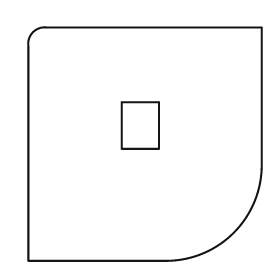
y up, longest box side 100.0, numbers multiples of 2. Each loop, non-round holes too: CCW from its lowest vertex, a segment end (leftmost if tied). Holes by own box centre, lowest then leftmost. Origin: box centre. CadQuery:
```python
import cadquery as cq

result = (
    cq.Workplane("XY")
    .moveTo(-50.0, -50.0)
    .lineTo(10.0, -50.0)
    .threePointArc((38.0, -38.0), (50.0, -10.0))
    .lineTo(50.0, 50.0)
    .lineTo(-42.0, 50.0)
    .threePointArc((-48.0, 48.0), (-50.0, 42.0))
    .close()
    .moveTo(-10.0, -2.0)
    .lineTo(6.0, -2.0)
    .lineTo(6.0, 18.0)
    .lineTo(-10.0, 18.0)
    .close()
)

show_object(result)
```